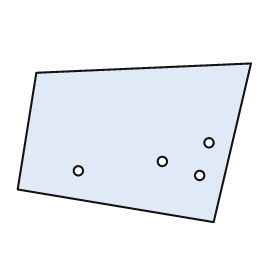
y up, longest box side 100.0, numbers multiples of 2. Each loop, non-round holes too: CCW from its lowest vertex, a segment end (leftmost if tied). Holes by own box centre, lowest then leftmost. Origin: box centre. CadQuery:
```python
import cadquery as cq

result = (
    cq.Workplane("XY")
    .moveTo(34.0, -34.0)
    .lineTo(50.0, 34.0)
    .lineTo(-42.0, 30.0)
    .lineTo(-50.0, -20.0)
    .close()
    .moveTo(28.0, -14.0)
    .circle(2.0)
    .moveTo(-24.0, -12.0)
    .circle(2.0)
    .moveTo(12.0, -8.0)
    .circle(2.0)
    .moveTo(32.0, 0.0)
    .circle(2.0)
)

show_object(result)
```